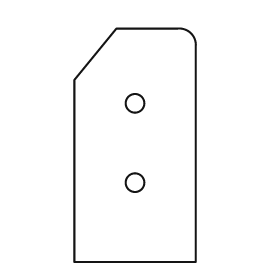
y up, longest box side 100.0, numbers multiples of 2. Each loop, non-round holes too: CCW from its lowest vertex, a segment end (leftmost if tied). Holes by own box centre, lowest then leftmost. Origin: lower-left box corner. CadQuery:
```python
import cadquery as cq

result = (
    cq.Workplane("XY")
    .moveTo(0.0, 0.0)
    .lineTo(52.0, 0.0)
    .lineTo(52.0, 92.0)
    .threePointArc((50.0, 98.0), (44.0, 100.0))
    .lineTo(18.0, 100.0)
    .lineTo(0.0, 78.0)
    .close()
    .moveTo(26.0, 34.0)
    .circle(4.0)
    .moveTo(26.0, 68.0)
    .circle(4.0)
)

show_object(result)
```